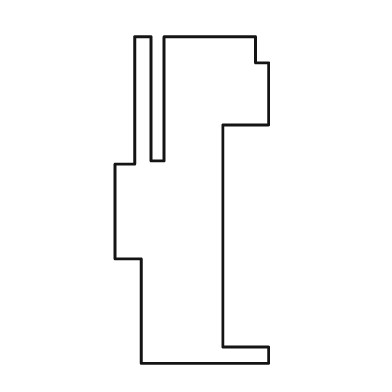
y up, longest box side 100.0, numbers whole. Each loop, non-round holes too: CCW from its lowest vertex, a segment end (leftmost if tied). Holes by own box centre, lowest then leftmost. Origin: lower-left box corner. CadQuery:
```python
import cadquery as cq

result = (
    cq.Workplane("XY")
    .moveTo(8.0, 0.0)
    .lineTo(47.0, 0.0)
    .lineTo(47.0, 5.0)
    .lineTo(33.0, 5.0)
    .lineTo(33.0, 73.0)
    .lineTo(47.0, 73.0)
    .lineTo(47.0, 92.0)
    .lineTo(43.0, 92.0)
    .lineTo(43.0, 100.0)
    .lineTo(15.0, 100.0)
    .lineTo(15.0, 62.0)
    .lineTo(11.0, 62.0)
    .lineTo(11.0, 100.0)
    .lineTo(6.0, 100.0)
    .lineTo(6.0, 61.0)
    .lineTo(0.0, 61.0)
    .lineTo(0.0, 32.0)
    .lineTo(8.0, 32.0)
    .close()
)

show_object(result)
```